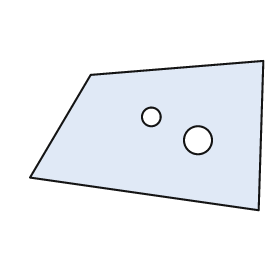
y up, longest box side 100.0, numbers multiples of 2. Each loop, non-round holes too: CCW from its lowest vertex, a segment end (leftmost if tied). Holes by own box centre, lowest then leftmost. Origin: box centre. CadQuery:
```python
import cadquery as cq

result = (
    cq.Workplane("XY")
    .moveTo(48.0, -32.0)
    .lineTo(50.0, 32.0)
    .lineTo(-24.0, 26.0)
    .lineTo(-50.0, -18.0)
    .close()
    .moveTo(22.0, -2.0)
    .circle(6.0)
    .moveTo(2.0, 8.0)
    .circle(4.0)
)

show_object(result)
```